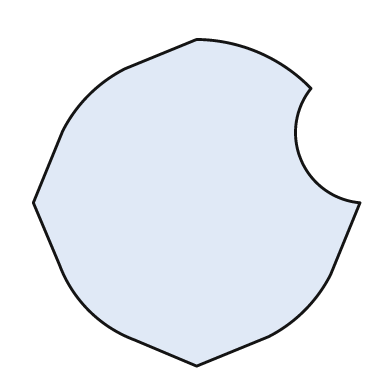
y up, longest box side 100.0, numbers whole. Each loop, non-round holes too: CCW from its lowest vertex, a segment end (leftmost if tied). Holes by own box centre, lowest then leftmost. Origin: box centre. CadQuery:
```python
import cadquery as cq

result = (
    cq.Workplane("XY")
    .moveTo(0.0, -50.0)
    .lineTo(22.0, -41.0)
    .threePointArc((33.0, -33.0), (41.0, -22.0))
    .lineTo(50.0, 0.0)
    .threePointArc((32.0, 13.0), (35.0, 35.0))
    .threePointArc((19.0, 46.0), (0.0, 50.0))
    .lineTo(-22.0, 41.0)
    .threePointArc((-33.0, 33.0), (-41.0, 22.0))
    .lineTo(-50.0, 0.0)
    .lineTo(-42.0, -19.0)
    .threePointArc((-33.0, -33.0), (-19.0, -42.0))
    .close()
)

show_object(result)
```